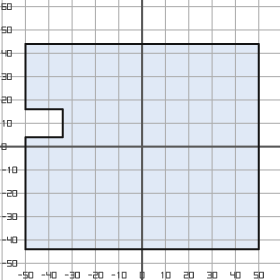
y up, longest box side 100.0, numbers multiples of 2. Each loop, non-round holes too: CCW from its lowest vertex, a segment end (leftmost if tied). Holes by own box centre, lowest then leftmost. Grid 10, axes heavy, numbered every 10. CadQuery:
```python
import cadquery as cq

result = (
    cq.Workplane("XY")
    .moveTo(-50.0, -44.0)
    .lineTo(50.0, -44.0)
    .lineTo(50.0, 44.0)
    .lineTo(-50.0, 44.0)
    .lineTo(-50.0, 16.0)
    .lineTo(-34.0, 16.0)
    .lineTo(-34.0, 4.0)
    .lineTo(-50.0, 4.0)
    .close()
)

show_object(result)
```